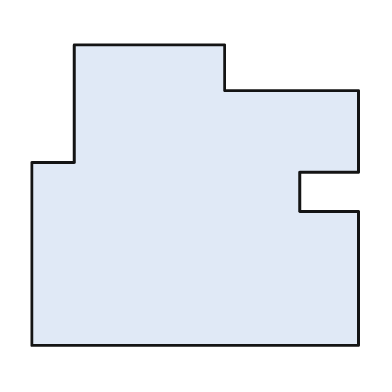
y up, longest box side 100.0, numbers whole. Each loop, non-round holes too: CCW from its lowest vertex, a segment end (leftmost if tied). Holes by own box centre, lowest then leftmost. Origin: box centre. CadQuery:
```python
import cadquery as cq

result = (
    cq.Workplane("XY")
    .moveTo(-50.0, -46.0)
    .lineTo(50.0, -46.0)
    .lineTo(50.0, -5.0)
    .lineTo(32.0, -5.0)
    .lineTo(32.0, 7.0)
    .lineTo(50.0, 7.0)
    .lineTo(50.0, 32.0)
    .lineTo(9.0, 32.0)
    .lineTo(9.0, 46.0)
    .lineTo(-37.0, 46.0)
    .lineTo(-37.0, 10.0)
    .lineTo(-50.0, 10.0)
    .close()
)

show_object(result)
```